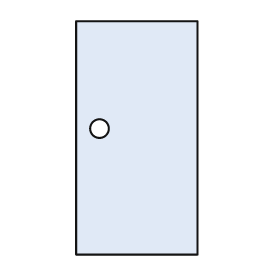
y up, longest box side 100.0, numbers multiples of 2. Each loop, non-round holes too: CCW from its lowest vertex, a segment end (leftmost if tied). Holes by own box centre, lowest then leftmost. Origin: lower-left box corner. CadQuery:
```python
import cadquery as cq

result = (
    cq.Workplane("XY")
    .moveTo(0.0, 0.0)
    .lineTo(52.0, 0.0)
    .lineTo(52.0, 100.0)
    .lineTo(0.0, 100.0)
    .close()
    .moveTo(10.0, 54.0)
    .circle(4.0)
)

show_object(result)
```